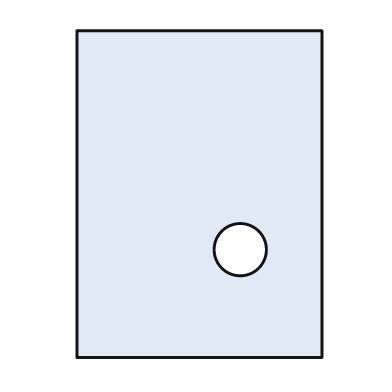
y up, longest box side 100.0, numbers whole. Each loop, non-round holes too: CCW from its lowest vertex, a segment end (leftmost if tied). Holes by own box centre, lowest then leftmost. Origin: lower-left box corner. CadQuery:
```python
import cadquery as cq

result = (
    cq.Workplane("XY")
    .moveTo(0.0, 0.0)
    .lineTo(75.0, 0.0)
    .lineTo(75.0, 100.0)
    .lineTo(0.0, 100.0)
    .close()
    .moveTo(50.0, 33.0)
    .circle(8.0)
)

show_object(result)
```